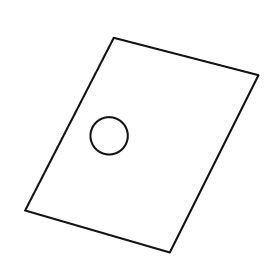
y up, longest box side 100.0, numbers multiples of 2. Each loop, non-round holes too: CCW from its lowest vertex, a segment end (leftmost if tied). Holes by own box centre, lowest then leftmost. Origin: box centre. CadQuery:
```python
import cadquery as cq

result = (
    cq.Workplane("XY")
    .moveTo(12.0, -46.0)
    .lineTo(50.0, 30.0)
    .lineTo(-12.0, 46.0)
    .lineTo(-50.0, -28.0)
    .close()
    .moveTo(-14.0, 4.0)
    .circle(8.0)
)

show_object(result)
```